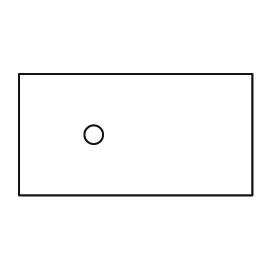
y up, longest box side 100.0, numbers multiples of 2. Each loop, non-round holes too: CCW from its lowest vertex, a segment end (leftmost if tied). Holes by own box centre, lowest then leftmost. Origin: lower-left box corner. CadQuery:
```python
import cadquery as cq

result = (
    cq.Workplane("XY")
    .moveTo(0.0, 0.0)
    .lineTo(100.0, 0.0)
    .lineTo(100.0, 52.0)
    .lineTo(0.0, 52.0)
    .close()
    .moveTo(32.0, 26.0)
    .circle(4.0)
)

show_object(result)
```